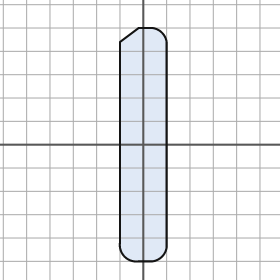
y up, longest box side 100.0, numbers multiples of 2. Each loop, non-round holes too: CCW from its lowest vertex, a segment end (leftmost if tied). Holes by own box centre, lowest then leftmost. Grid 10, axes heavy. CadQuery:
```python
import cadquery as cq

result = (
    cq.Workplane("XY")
    .moveTo(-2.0, -50.0)
    .lineTo(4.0, -50.0)
    .threePointArc((8.0, -48.0), (10.0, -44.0))
    .lineTo(10.0, 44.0)
    .threePointArc((8.0, 48.0), (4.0, 50.0))
    .lineTo(-2.0, 50.0)
    .lineTo(-10.0, 44.0)
    .lineTo(-10.0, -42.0)
    .threePointArc((-8.0, -48.0), (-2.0, -50.0))
    .close()
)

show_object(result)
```